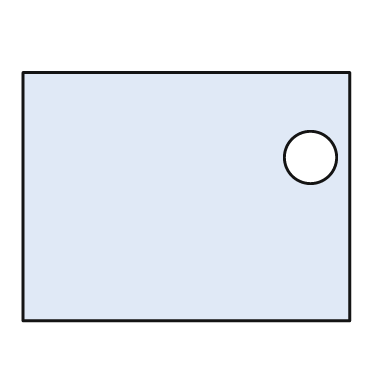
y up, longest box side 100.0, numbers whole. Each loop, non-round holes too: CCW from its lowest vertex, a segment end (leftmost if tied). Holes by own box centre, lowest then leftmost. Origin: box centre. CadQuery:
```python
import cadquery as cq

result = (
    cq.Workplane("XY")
    .moveTo(-50.0, -38.0)
    .lineTo(50.0, -38.0)
    .lineTo(50.0, 38.0)
    .lineTo(-50.0, 38.0)
    .close()
    .moveTo(38.0, 12.0)
    .circle(8.0)
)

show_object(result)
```